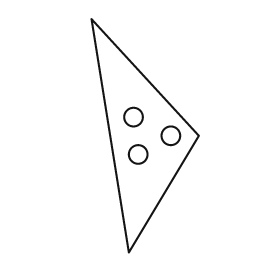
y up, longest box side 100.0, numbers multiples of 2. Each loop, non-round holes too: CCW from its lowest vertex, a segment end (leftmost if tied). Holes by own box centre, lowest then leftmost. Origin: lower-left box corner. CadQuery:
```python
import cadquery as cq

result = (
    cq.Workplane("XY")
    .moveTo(16.0, 0.0)
    .lineTo(46.0, 50.0)
    .lineTo(0.0, 100.0)
    .close()
    .moveTo(20.0, 42.0)
    .circle(4.0)
    .moveTo(34.0, 50.0)
    .circle(4.0)
    .moveTo(18.0, 58.0)
    .circle(4.0)
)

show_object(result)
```